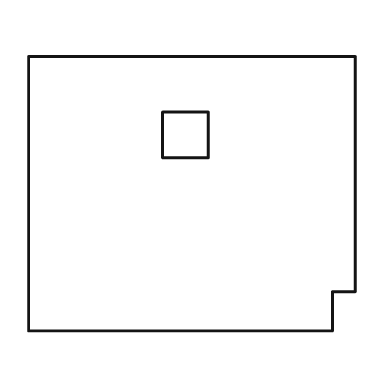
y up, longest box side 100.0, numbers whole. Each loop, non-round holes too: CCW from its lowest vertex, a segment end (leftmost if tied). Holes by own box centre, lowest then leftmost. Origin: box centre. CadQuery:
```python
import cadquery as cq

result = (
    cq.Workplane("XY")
    .moveTo(-50.0, -42.0)
    .lineTo(43.0, -42.0)
    .lineTo(43.0, -30.0)
    .lineTo(50.0, -30.0)
    .lineTo(50.0, 42.0)
    .lineTo(-50.0, 42.0)
    .close()
    .moveTo(-9.0, 11.0)
    .lineTo(5.0, 11.0)
    .lineTo(5.0, 25.0)
    .lineTo(-9.0, 25.0)
    .close()
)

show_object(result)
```